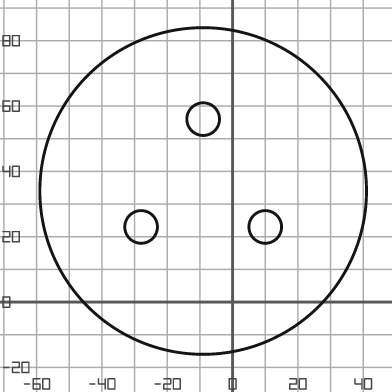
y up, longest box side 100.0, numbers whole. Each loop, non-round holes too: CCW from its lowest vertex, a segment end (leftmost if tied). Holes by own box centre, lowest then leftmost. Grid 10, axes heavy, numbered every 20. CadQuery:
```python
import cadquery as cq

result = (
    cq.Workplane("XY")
    .moveTo(-9.0, 34.0)
    .circle(50.0)
    .moveTo(-28.0, 23.0)
    .circle(5.0)
    .moveTo(10.0, 23.0)
    .circle(5.0)
    .moveTo(-9.0, 56.0)
    .circle(5.0)
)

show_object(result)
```